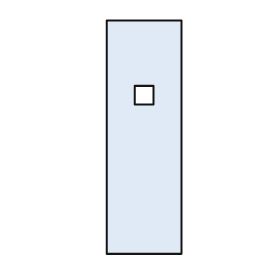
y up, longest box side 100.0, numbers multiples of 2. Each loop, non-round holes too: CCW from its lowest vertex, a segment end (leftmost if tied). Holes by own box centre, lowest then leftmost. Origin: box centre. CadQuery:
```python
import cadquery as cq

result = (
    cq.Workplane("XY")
    .moveTo(-16.0, -50.0)
    .lineTo(16.0, -50.0)
    .lineTo(16.0, 50.0)
    .lineTo(-16.0, 50.0)
    .close()
    .moveTo(-4.0, 14.0)
    .lineTo(4.0, 14.0)
    .lineTo(4.0, 22.0)
    .lineTo(-4.0, 22.0)
    .close()
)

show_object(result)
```